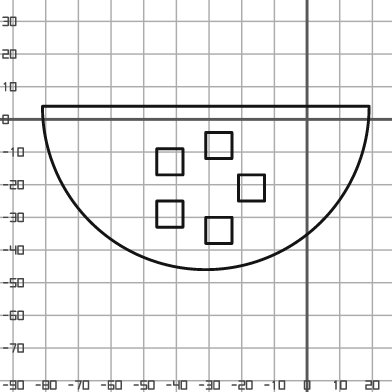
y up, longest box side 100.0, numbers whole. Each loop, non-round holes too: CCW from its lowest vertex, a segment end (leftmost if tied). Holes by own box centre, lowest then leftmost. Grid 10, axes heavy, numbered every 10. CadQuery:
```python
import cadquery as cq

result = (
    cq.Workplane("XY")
    .moveTo(-81.0, 4.0)
    .threePointArc((-31.0, -46.0), (19.0, 4.0))
    .close()
    .moveTo(-31.0, -38.0)
    .lineTo(-23.0, -38.0)
    .lineTo(-23.0, -30.0)
    .lineTo(-31.0, -30.0)
    .close()
    .moveTo(-46.0, -33.0)
    .lineTo(-38.0, -33.0)
    .lineTo(-38.0, -25.0)
    .lineTo(-46.0, -25.0)
    .close()
    .moveTo(-21.0, -25.0)
    .lineTo(-13.0, -25.0)
    .lineTo(-13.0, -17.0)
    .lineTo(-21.0, -17.0)
    .close()
    .moveTo(-46.0, -17.0)
    .lineTo(-38.0, -17.0)
    .lineTo(-38.0, -9.0)
    .lineTo(-46.0, -9.0)
    .close()
    .moveTo(-31.0, -12.0)
    .lineTo(-23.0, -12.0)
    .lineTo(-23.0, -4.0)
    .lineTo(-31.0, -4.0)
    .close()
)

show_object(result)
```